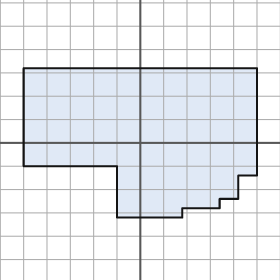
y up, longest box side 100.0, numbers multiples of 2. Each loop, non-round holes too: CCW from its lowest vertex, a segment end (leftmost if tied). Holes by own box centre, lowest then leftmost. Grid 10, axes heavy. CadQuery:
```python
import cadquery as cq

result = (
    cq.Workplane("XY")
    .moveTo(-10.0, -32.0)
    .lineTo(18.0, -32.0)
    .lineTo(18.0, -28.0)
    .lineTo(34.0, -28.0)
    .lineTo(34.0, -24.0)
    .lineTo(42.0, -24.0)
    .lineTo(42.0, -14.0)
    .lineTo(50.0, -14.0)
    .lineTo(50.0, 32.0)
    .lineTo(-50.0, 32.0)
    .lineTo(-50.0, -10.0)
    .lineTo(-10.0, -10.0)
    .close()
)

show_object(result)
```